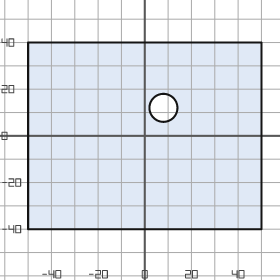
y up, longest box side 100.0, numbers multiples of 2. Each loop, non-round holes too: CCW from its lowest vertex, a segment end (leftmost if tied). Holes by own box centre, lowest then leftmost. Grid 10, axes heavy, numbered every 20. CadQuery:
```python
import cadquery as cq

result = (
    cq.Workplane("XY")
    .moveTo(-50.0, -40.0)
    .lineTo(50.0, -40.0)
    .lineTo(50.0, 40.0)
    .lineTo(-50.0, 40.0)
    .close()
    .moveTo(8.0, 12.0)
    .circle(6.0)
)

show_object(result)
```